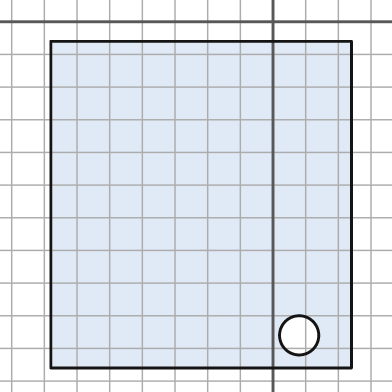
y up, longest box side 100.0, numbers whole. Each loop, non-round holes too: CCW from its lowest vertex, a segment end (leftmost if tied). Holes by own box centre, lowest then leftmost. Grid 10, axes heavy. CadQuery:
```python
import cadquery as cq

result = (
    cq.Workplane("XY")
    .moveTo(-68.0, -106.0)
    .lineTo(24.0, -106.0)
    .lineTo(24.0, -6.0)
    .lineTo(-68.0, -6.0)
    .close()
    .moveTo(8.0, -96.0)
    .circle(6.0)
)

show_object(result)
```